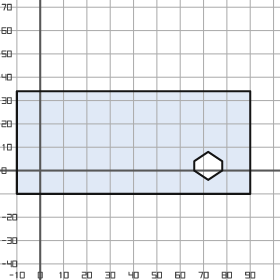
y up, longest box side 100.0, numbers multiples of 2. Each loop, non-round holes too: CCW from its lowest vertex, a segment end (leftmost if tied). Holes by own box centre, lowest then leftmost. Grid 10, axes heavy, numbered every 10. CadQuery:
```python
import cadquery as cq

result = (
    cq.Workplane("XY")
    .moveTo(-10.0, -10.0)
    .lineTo(90.0, -10.0)
    .lineTo(90.0, 34.0)
    .lineTo(-10.0, 34.0)
    .close()
    .moveTo(72.0, -4.0)
    .lineTo(78.0, 0.0)
    .lineTo(78.0, 4.0)
    .lineTo(72.0, 8.0)
    .lineTo(66.0, 4.0)
    .lineTo(66.0, 0.0)
    .close()
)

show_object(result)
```